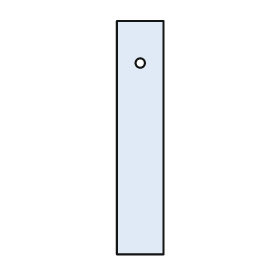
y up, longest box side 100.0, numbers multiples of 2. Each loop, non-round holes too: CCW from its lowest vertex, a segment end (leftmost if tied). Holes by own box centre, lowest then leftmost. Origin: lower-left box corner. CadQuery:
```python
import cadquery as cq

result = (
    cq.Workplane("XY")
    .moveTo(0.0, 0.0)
    .lineTo(20.0, 0.0)
    .lineTo(20.0, 100.0)
    .lineTo(0.0, 100.0)
    .close()
    .moveTo(10.0, 82.0)
    .circle(2.0)
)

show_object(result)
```